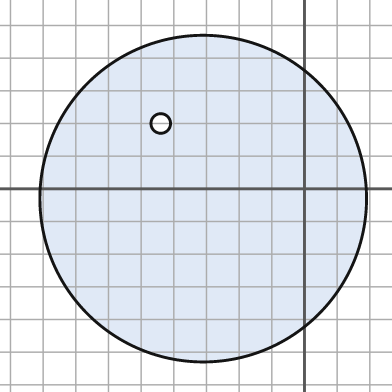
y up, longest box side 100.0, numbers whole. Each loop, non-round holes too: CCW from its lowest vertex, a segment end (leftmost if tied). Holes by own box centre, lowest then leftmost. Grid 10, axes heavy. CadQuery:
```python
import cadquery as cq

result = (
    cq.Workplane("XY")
    .moveTo(-31.0, -3.0)
    .circle(50.0)
    .moveTo(-44.0, 20.0)
    .circle(3.0)
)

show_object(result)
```